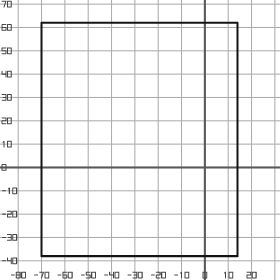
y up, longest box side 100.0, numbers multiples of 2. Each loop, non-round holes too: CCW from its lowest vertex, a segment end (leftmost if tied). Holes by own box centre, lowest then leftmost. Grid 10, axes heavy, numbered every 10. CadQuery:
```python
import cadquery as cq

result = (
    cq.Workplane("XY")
    .moveTo(-70.0, -38.0)
    .lineTo(14.0, -38.0)
    .lineTo(14.0, 62.0)
    .lineTo(-70.0, 62.0)
    .close()
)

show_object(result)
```